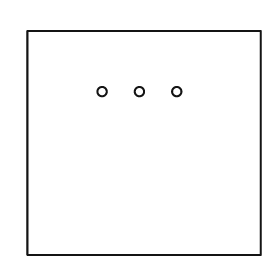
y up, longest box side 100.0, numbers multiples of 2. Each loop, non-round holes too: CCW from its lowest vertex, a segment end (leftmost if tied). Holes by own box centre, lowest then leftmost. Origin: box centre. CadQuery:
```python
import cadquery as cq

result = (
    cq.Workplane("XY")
    .moveTo(-50.0, -48.0)
    .lineTo(50.0, -48.0)
    .lineTo(50.0, 48.0)
    .lineTo(-50.0, 48.0)
    .close()
    .moveTo(-18.0, 22.0)
    .circle(2.0)
    .moveTo(-2.0, 22.0)
    .circle(2.0)
    .moveTo(14.0, 22.0)
    .circle(2.0)
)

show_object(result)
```